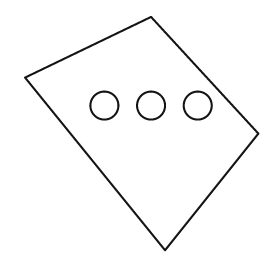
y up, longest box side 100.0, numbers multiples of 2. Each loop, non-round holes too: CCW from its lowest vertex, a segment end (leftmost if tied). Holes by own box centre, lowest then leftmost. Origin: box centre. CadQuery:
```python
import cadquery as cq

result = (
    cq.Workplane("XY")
    .moveTo(10.0, -50.0)
    .lineTo(50.0, 0.0)
    .lineTo(4.0, 50.0)
    .lineTo(-50.0, 24.0)
    .close()
    .moveTo(-16.0, 12.0)
    .circle(6.0)
    .moveTo(4.0, 12.0)
    .circle(6.0)
    .moveTo(24.0, 12.0)
    .circle(6.0)
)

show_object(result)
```